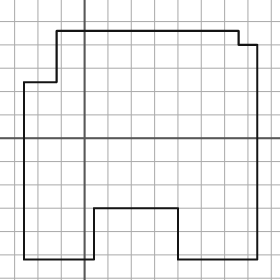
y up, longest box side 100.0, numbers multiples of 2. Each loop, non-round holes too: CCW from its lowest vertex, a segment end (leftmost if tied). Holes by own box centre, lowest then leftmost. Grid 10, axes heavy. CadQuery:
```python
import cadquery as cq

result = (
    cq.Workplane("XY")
    .moveTo(-26.0, -52.0)
    .lineTo(4.0, -52.0)
    .lineTo(4.0, -30.0)
    .lineTo(40.0, -30.0)
    .lineTo(40.0, -52.0)
    .lineTo(74.0, -52.0)
    .lineTo(74.0, 40.0)
    .lineTo(66.0, 40.0)
    .lineTo(66.0, 46.0)
    .lineTo(-12.0, 46.0)
    .lineTo(-12.0, 24.0)
    .lineTo(-26.0, 24.0)
    .close()
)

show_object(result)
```